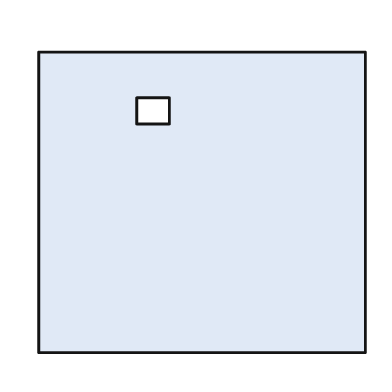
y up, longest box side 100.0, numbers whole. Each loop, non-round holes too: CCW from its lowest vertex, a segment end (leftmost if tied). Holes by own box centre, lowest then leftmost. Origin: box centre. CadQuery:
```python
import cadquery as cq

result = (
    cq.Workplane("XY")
    .moveTo(-50.0, -46.0)
    .lineTo(50.0, -46.0)
    .lineTo(50.0, 46.0)
    .lineTo(-50.0, 46.0)
    .close()
    .moveTo(-20.0, 24.0)
    .lineTo(-10.0, 24.0)
    .lineTo(-10.0, 32.0)
    .lineTo(-20.0, 32.0)
    .close()
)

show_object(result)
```